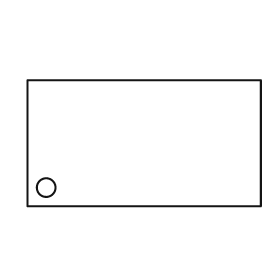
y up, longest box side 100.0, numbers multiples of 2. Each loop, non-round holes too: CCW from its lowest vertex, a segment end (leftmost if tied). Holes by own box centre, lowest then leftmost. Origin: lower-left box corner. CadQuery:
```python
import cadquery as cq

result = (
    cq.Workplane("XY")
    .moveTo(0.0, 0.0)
    .lineTo(100.0, 0.0)
    .lineTo(100.0, 54.0)
    .lineTo(0.0, 54.0)
    .close()
    .moveTo(8.0, 8.0)
    .circle(4.0)
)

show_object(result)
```